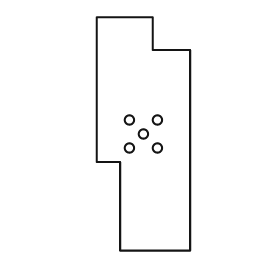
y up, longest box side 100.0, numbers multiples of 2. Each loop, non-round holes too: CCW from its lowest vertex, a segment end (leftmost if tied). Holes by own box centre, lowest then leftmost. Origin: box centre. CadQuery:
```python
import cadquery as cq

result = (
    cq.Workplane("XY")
    .moveTo(-10.0, -50.0)
    .lineTo(20.0, -50.0)
    .lineTo(20.0, 36.0)
    .lineTo(4.0, 36.0)
    .lineTo(4.0, 50.0)
    .lineTo(-20.0, 50.0)
    .lineTo(-20.0, -12.0)
    .lineTo(-10.0, -12.0)
    .close()
    .moveTo(-6.0, -6.0)
    .circle(2.0)
    .moveTo(6.0, -6.0)
    .circle(2.0)
    .moveTo(0.0, 0.0)
    .circle(2.0)
    .moveTo(-6.0, 6.0)
    .circle(2.0)
    .moveTo(6.0, 6.0)
    .circle(2.0)
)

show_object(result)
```